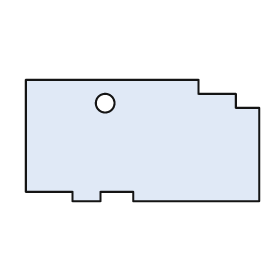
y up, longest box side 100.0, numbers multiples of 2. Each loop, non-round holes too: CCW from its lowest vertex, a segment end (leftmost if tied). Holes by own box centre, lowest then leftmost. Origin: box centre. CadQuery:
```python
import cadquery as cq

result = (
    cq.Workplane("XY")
    .moveTo(-30.0, -26.0)
    .lineTo(-18.0, -26.0)
    .lineTo(-18.0, -22.0)
    .lineTo(-4.0, -22.0)
    .lineTo(-4.0, -26.0)
    .lineTo(50.0, -26.0)
    .lineTo(50.0, 14.0)
    .lineTo(40.0, 14.0)
    .lineTo(40.0, 20.0)
    .lineTo(24.0, 20.0)
    .lineTo(24.0, 26.0)
    .lineTo(-50.0, 26.0)
    .lineTo(-50.0, -22.0)
    .lineTo(-30.0, -22.0)
    .close()
    .moveTo(-16.0, 16.0)
    .circle(4.0)
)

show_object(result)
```